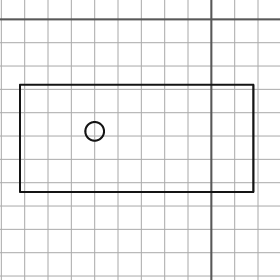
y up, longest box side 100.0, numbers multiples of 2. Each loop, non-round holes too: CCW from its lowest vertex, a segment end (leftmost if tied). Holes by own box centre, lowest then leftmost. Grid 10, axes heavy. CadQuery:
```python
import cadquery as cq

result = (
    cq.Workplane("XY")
    .moveTo(-82.0, -74.0)
    .lineTo(18.0, -74.0)
    .lineTo(18.0, -28.0)
    .lineTo(-82.0, -28.0)
    .close()
    .moveTo(-50.0, -48.0)
    .circle(4.0)
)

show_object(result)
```